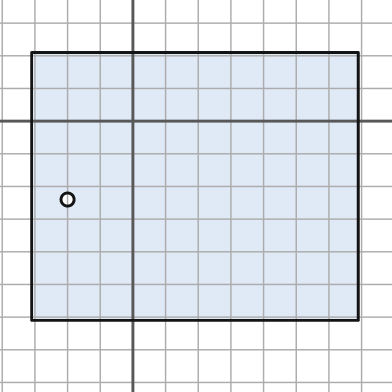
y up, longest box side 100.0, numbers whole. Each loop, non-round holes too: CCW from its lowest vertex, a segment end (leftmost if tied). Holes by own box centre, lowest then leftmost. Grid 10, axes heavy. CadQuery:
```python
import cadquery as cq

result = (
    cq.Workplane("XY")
    .moveTo(-31.0, -61.0)
    .lineTo(69.0, -61.0)
    .lineTo(69.0, 21.0)
    .lineTo(-31.0, 21.0)
    .close()
    .moveTo(-20.0, -24.0)
    .circle(2.0)
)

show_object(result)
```